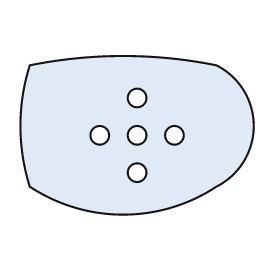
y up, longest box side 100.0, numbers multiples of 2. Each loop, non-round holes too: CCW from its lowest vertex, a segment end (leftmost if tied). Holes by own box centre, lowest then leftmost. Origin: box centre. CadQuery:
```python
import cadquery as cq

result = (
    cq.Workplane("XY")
    .moveTo(-46.0, -22.0)
    .threePointArc((-6.0, -34.0), (34.0, -22.0))
    .threePointArc((50.0, 4.0), (34.0, 30.0))
    .threePointArc((-6.0, 34.0), (-46.0, 30.0))
    .threePointArc((-50.0, 4.0), (-46.0, -22.0))
    .close()
    .moveTo(0.0, -16.0)
    .circle(4.0)
    .moveTo(-16.0, 0.0)
    .circle(4.0)
    .moveTo(0.0, 0.0)
    .circle(4.0)
    .moveTo(16.0, 0.0)
    .circle(4.0)
    .moveTo(0.0, 16.0)
    .circle(4.0)
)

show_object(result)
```